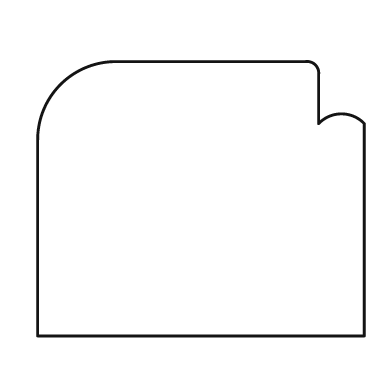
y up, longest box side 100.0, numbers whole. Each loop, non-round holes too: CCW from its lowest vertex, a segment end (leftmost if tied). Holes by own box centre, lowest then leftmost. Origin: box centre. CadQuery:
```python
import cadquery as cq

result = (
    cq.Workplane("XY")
    .moveTo(-50.0, -42.0)
    .lineTo(50.0, -42.0)
    .lineTo(50.0, 23.0)
    .threePointArc((43.0, 26.0), (36.0, 23.0))
    .lineTo(36.0, 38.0)
    .threePointArc((35.0, 41.0), (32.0, 42.0))
    .lineTo(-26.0, 42.0)
    .threePointArc((-43.0, 35.0), (-50.0, 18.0))
    .close()
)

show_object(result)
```